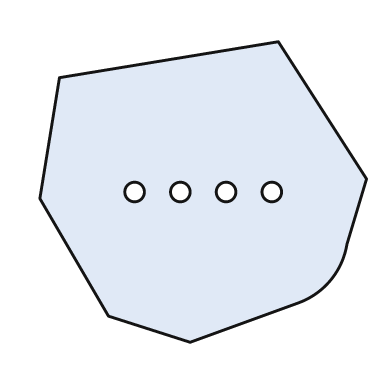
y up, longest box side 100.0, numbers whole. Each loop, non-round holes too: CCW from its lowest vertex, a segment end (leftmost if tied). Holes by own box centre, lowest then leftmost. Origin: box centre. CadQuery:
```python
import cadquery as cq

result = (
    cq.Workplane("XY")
    .moveTo(-4.0, -46.0)
    .lineTo(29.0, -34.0)
    .threePointArc((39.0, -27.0), (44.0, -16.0))
    .lineTo(50.0, 4.0)
    .lineTo(23.0, 46.0)
    .lineTo(-44.0, 35.0)
    .lineTo(-50.0, -2.0)
    .lineTo(-29.0, -38.0)
    .close()
    .moveTo(-21.0, 0.0)
    .circle(3.0)
    .moveTo(-7.0, 0.0)
    .circle(3.0)
    .moveTo(7.0, 0.0)
    .circle(3.0)
    .moveTo(21.0, 0.0)
    .circle(3.0)
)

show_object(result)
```